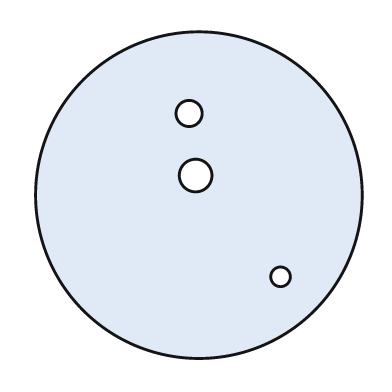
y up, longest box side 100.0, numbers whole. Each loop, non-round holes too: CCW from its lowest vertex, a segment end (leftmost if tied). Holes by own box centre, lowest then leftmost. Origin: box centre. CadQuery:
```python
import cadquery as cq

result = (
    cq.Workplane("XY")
    .moveTo(0.0, 0.0)
    .circle(50.0)
    .moveTo(25.0, -25.0)
    .circle(3.0)
    .moveTo(-1.0, 6.0)
    .circle(5.0)
    .moveTo(-3.0, 25.0)
    .circle(4.0)
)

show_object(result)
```